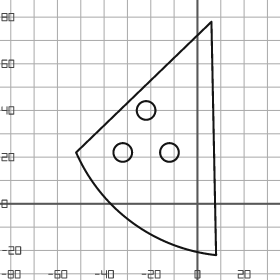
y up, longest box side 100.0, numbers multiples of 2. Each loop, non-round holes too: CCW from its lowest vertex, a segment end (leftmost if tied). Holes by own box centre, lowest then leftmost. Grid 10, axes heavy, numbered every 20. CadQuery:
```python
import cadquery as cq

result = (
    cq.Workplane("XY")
    .moveTo(8.0, -22.0)
    .lineTo(6.0, 78.0)
    .lineTo(-52.0, 22.0)
    .threePointArc((-28.0, -8.0), (8.0, -22.0))
    .close()
    .moveTo(-32.0, 22.0)
    .circle(4.0)
    .moveTo(-12.0, 22.0)
    .circle(4.0)
    .moveTo(-22.0, 40.0)
    .circle(4.0)
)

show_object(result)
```